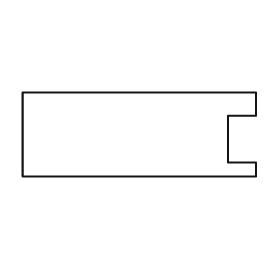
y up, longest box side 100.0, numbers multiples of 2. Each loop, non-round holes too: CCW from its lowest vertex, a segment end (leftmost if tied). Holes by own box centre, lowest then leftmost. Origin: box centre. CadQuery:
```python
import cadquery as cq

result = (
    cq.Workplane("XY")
    .moveTo(-50.0, -18.0)
    .lineTo(50.0, -18.0)
    .lineTo(50.0, -12.0)
    .lineTo(38.0, -12.0)
    .lineTo(38.0, 8.0)
    .lineTo(50.0, 8.0)
    .lineTo(50.0, 18.0)
    .lineTo(-50.0, 18.0)
    .close()
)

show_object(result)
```